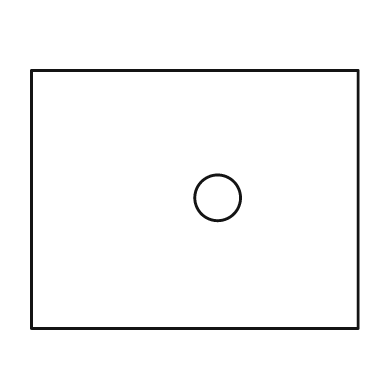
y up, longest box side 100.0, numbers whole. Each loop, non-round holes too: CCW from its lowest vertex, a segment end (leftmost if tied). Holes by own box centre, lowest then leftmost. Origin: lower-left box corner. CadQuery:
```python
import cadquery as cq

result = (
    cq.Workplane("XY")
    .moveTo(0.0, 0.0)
    .lineTo(100.0, 0.0)
    .lineTo(100.0, 79.0)
    .lineTo(0.0, 79.0)
    .close()
    .moveTo(57.0, 40.0)
    .circle(7.0)
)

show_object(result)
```